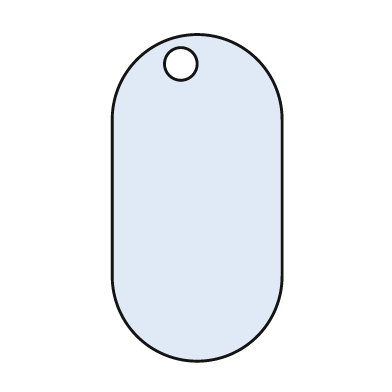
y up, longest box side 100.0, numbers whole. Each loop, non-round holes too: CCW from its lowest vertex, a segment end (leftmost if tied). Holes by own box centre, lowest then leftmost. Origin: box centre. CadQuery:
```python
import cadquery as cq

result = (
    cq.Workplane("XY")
    .moveTo(-26.0, -24.0)
    .threePointArc((0.0, -50.0), (26.0, -24.0))
    .lineTo(26.0, 24.0)
    .threePointArc((0.0, 50.0), (-26.0, 24.0))
    .close()
    .moveTo(-5.0, 41.0)
    .circle(5.0)
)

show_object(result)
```